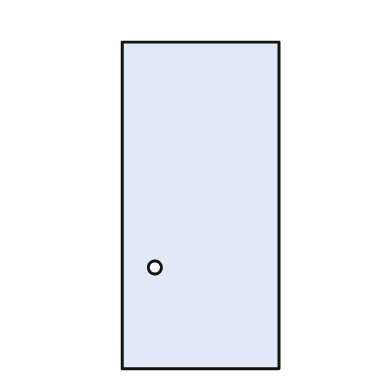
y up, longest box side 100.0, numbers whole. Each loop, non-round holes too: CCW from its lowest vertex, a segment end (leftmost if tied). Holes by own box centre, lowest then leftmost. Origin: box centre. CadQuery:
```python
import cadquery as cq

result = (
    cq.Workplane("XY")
    .moveTo(-24.0, -50.0)
    .lineTo(24.0, -50.0)
    .lineTo(24.0, 50.0)
    .lineTo(-24.0, 50.0)
    .close()
    .moveTo(-14.0, -19.0)
    .circle(2.0)
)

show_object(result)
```